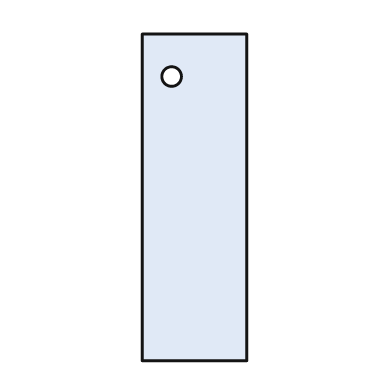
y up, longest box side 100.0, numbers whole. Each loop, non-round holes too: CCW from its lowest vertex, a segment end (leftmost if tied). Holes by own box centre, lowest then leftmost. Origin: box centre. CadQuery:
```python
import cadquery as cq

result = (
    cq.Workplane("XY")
    .moveTo(-16.0, -50.0)
    .lineTo(16.0, -50.0)
    .lineTo(16.0, 50.0)
    .lineTo(-16.0, 50.0)
    .close()
    .moveTo(-7.0, 37.0)
    .circle(3.0)
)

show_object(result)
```